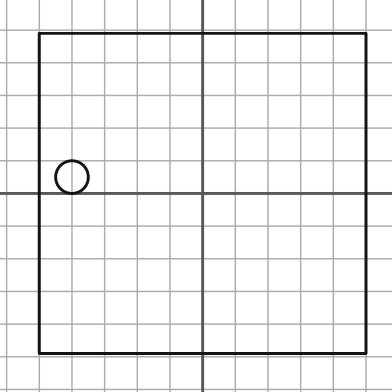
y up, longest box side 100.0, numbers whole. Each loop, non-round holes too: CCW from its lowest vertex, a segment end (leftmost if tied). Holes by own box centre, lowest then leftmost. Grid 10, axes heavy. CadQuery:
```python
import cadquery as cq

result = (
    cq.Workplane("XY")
    .moveTo(-50.0, -49.0)
    .lineTo(50.0, -49.0)
    .lineTo(50.0, 49.0)
    .lineTo(-50.0, 49.0)
    .close()
    .moveTo(-40.0, 5.0)
    .circle(5.0)
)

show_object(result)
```